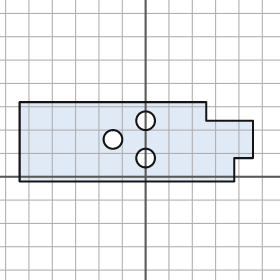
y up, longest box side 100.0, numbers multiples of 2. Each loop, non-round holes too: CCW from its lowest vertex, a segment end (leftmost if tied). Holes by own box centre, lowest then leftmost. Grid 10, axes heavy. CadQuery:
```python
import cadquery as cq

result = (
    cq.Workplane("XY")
    .moveTo(-54.0, -2.0)
    .lineTo(38.0, -2.0)
    .lineTo(38.0, 8.0)
    .lineTo(46.0, 8.0)
    .lineTo(46.0, 24.0)
    .lineTo(26.0, 24.0)
    .lineTo(26.0, 32.0)
    .lineTo(-54.0, 32.0)
    .close()
    .moveTo(0.0, 8.0)
    .circle(4.0)
    .moveTo(-14.0, 16.0)
    .circle(4.0)
    .moveTo(0.0, 24.0)
    .circle(4.0)
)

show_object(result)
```